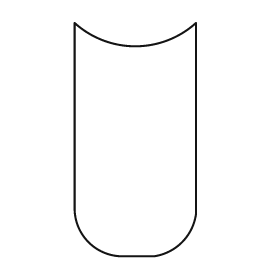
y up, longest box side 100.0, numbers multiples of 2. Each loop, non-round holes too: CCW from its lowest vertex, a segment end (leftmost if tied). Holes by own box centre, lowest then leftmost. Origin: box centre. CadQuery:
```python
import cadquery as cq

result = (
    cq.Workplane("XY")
    .moveTo(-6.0, -50.0)
    .lineTo(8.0, -50.0)
    .threePointArc((20.0, -44.0), (26.0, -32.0))
    .lineTo(26.0, 50.0)
    .threePointArc((0.0, 40.0), (-26.0, 50.0))
    .lineTo(-26.0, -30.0)
    .threePointArc((-20.0, -44.0), (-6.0, -50.0))
    .close()
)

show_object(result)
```